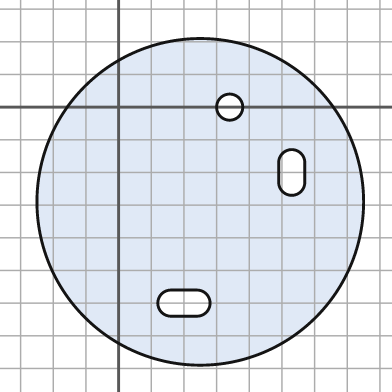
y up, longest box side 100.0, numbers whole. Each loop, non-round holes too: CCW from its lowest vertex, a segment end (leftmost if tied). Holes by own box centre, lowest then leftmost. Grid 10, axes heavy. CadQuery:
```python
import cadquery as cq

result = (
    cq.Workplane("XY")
    .moveTo(25.0, -29.0)
    .circle(50.0)
    .moveTo(16.0, -64.0)
    .lineTo(24.0, -64.0)
    .threePointArc((28.0, -60.0), (24.0, -56.0))
    .lineTo(16.0, -56.0)
    .threePointArc((12.0, -60.0), (16.0, -64.0))
    .close()
    .moveTo(49.0, -23.0)
    .threePointArc((53.0, -27.0), (57.0, -23.0))
    .lineTo(57.0, -17.0)
    .threePointArc((53.0, -13.0), (49.0, -17.0))
    .close()
    .moveTo(34.0, 0.0)
    .circle(4.0)
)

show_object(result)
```